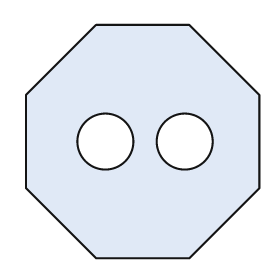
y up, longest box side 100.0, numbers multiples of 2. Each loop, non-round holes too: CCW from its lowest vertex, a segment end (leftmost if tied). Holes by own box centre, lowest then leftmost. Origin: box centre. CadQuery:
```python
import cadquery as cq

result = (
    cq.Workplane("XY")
    .moveTo(-20.0, -50.0)
    .lineTo(20.0, -50.0)
    .lineTo(50.0, -20.0)
    .lineTo(50.0, 20.0)
    .lineTo(20.0, 50.0)
    .lineTo(-20.0, 50.0)
    .lineTo(-50.0, 20.0)
    .lineTo(-50.0, -20.0)
    .close()
    .moveTo(-16.0, 0.0)
    .circle(12.0)
    .moveTo(18.0, 0.0)
    .circle(12.0)
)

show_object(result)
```